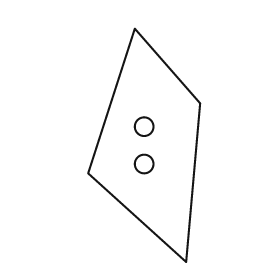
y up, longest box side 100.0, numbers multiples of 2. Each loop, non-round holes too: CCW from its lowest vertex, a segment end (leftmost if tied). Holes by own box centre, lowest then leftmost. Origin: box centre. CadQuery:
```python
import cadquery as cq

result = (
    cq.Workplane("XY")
    .moveTo(18.0, -50.0)
    .lineTo(24.0, 18.0)
    .lineTo(-4.0, 50.0)
    .lineTo(-24.0, -12.0)
    .close()
    .moveTo(0.0, -8.0)
    .circle(4.0)
    .moveTo(0.0, 8.0)
    .circle(4.0)
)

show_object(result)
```